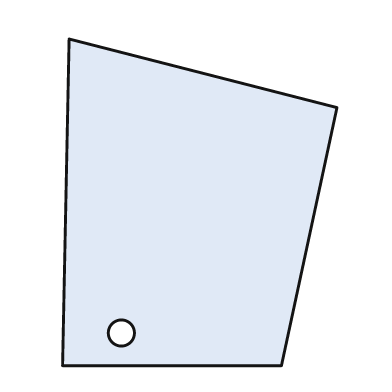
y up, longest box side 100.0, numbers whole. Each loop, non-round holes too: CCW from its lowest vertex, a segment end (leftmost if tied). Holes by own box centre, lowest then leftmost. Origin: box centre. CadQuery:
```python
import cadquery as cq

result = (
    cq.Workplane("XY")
    .moveTo(-42.0, -50.0)
    .lineTo(25.0, -50.0)
    .lineTo(42.0, 29.0)
    .lineTo(-40.0, 50.0)
    .close()
    .moveTo(-24.0, -40.0)
    .circle(4.0)
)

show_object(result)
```